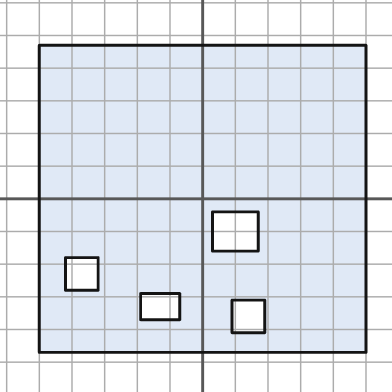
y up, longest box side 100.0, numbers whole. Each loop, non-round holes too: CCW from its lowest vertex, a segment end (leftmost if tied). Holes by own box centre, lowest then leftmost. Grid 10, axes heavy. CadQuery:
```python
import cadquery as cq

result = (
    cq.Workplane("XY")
    .moveTo(-50.0, -47.0)
    .lineTo(50.0, -47.0)
    .lineTo(50.0, 47.0)
    .lineTo(-50.0, 47.0)
    .close()
    .moveTo(9.0, -41.0)
    .lineTo(19.0, -41.0)
    .lineTo(19.0, -31.0)
    .lineTo(9.0, -31.0)
    .close()
    .moveTo(-19.0, -37.0)
    .lineTo(-7.0, -37.0)
    .lineTo(-7.0, -29.0)
    .lineTo(-19.0, -29.0)
    .close()
    .moveTo(-42.0, -28.0)
    .lineTo(-32.0, -28.0)
    .lineTo(-32.0, -18.0)
    .lineTo(-42.0, -18.0)
    .close()
    .moveTo(3.0, -16.0)
    .lineTo(17.0, -16.0)
    .lineTo(17.0, -4.0)
    .lineTo(3.0, -4.0)
    .close()
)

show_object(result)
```